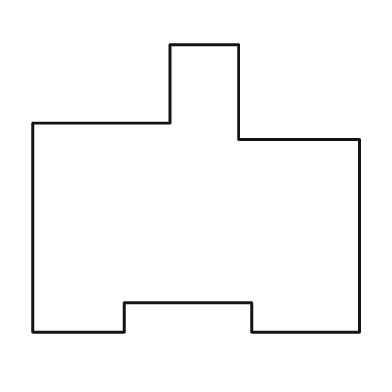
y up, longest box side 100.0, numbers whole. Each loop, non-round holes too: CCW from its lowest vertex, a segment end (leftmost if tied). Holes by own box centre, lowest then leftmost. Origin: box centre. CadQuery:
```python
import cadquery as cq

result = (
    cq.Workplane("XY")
    .moveTo(-50.0, -44.0)
    .lineTo(-22.0, -44.0)
    .lineTo(-22.0, -35.0)
    .lineTo(17.0, -35.0)
    .lineTo(17.0, -44.0)
    .lineTo(50.0, -44.0)
    .lineTo(50.0, 15.0)
    .lineTo(13.0, 15.0)
    .lineTo(13.0, 44.0)
    .lineTo(-8.0, 44.0)
    .lineTo(-8.0, 20.0)
    .lineTo(-50.0, 20.0)
    .close()
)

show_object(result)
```